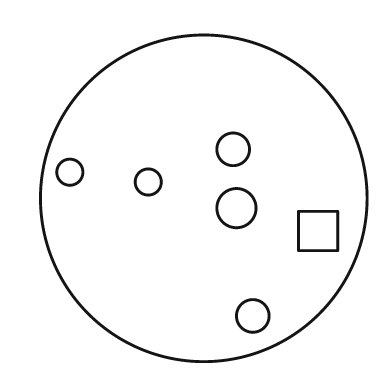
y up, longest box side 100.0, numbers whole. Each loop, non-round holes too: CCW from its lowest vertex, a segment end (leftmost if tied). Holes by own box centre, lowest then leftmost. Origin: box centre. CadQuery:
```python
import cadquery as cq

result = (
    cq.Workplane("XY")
    .moveTo(0.0, 0.0)
    .circle(50.0)
    .moveTo(15.0, -36.0)
    .circle(5.0)
    .moveTo(29.0, -16.0)
    .lineTo(41.0, -16.0)
    .lineTo(41.0, -4.0)
    .lineTo(29.0, -4.0)
    .close()
    .moveTo(10.0, -3.0)
    .circle(6.0)
    .moveTo(-17.0, 5.0)
    .circle(4.0)
    .moveTo(-41.0, 8.0)
    .circle(4.0)
    .moveTo(9.0, 15.0)
    .circle(5.0)
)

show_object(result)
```